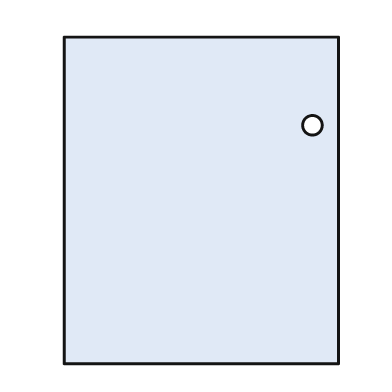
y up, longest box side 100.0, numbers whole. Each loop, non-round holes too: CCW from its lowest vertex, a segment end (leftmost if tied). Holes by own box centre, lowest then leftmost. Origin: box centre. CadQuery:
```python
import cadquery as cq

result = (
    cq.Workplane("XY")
    .moveTo(-42.0, -50.0)
    .lineTo(42.0, -50.0)
    .lineTo(42.0, 50.0)
    .lineTo(-42.0, 50.0)
    .close()
    .moveTo(34.0, 23.0)
    .circle(3.0)
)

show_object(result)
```